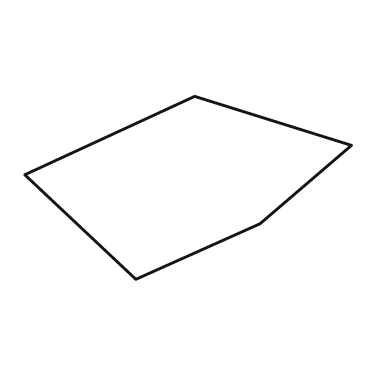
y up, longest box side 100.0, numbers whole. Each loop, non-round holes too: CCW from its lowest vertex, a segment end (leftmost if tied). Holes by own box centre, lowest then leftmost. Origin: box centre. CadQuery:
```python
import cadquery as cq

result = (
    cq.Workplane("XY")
    .moveTo(-16.0, -28.0)
    .lineTo(22.0, -11.0)
    .lineTo(50.0, 13.0)
    .lineTo(2.0, 28.0)
    .lineTo(-50.0, 4.0)
    .close()
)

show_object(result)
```